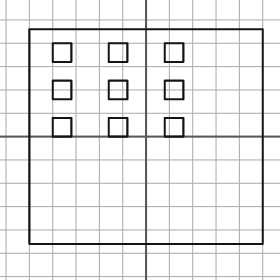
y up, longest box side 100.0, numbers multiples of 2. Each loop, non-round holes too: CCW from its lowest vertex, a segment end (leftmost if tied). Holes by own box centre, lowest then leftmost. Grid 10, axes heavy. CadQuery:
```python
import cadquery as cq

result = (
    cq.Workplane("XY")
    .moveTo(-50.0, -46.0)
    .lineTo(50.0, -46.0)
    .lineTo(50.0, 46.0)
    .lineTo(-50.0, 46.0)
    .close()
    .moveTo(-40.0, 0.0)
    .lineTo(-32.0, 0.0)
    .lineTo(-32.0, 8.0)
    .lineTo(-40.0, 8.0)
    .close()
    .moveTo(-16.0, 0.0)
    .lineTo(-8.0, 0.0)
    .lineTo(-8.0, 8.0)
    .lineTo(-16.0, 8.0)
    .close()
    .moveTo(8.0, 0.0)
    .lineTo(16.0, 0.0)
    .lineTo(16.0, 8.0)
    .lineTo(8.0, 8.0)
    .close()
    .moveTo(-40.0, 16.0)
    .lineTo(-32.0, 16.0)
    .lineTo(-32.0, 24.0)
    .lineTo(-40.0, 24.0)
    .close()
    .moveTo(-16.0, 16.0)
    .lineTo(-8.0, 16.0)
    .lineTo(-8.0, 24.0)
    .lineTo(-16.0, 24.0)
    .close()
    .moveTo(8.0, 16.0)
    .lineTo(16.0, 16.0)
    .lineTo(16.0, 24.0)
    .lineTo(8.0, 24.0)
    .close()
    .moveTo(-40.0, 32.0)
    .lineTo(-32.0, 32.0)
    .lineTo(-32.0, 40.0)
    .lineTo(-40.0, 40.0)
    .close()
    .moveTo(-16.0, 32.0)
    .lineTo(-8.0, 32.0)
    .lineTo(-8.0, 40.0)
    .lineTo(-16.0, 40.0)
    .close()
    .moveTo(8.0, 32.0)
    .lineTo(16.0, 32.0)
    .lineTo(16.0, 40.0)
    .lineTo(8.0, 40.0)
    .close()
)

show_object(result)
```